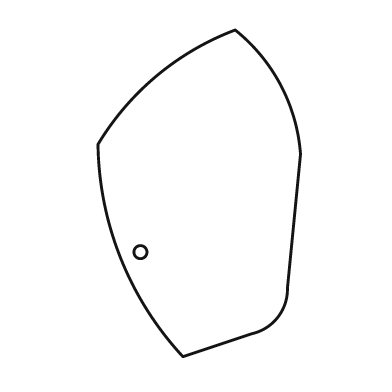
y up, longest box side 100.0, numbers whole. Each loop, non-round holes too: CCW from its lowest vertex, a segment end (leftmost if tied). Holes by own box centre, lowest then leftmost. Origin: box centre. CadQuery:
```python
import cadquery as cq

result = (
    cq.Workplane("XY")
    .moveTo(-5.0, -50.0)
    .lineTo(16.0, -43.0)
    .threePointArc((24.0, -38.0), (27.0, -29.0))
    .lineTo(31.0, 12.0)
    .threePointArc((25.0, 33.0), (11.0, 50.0))
    .threePointArc((-13.0, 36.0), (-31.0, 15.0))
    .threePointArc((-24.0, -20.0), (-5.0, -50.0))
    .close()
    .moveTo(-18.0, -18.0)
    .circle(2.0)
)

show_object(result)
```